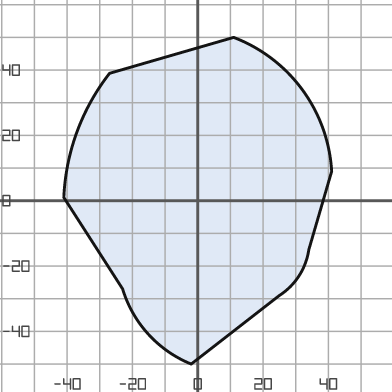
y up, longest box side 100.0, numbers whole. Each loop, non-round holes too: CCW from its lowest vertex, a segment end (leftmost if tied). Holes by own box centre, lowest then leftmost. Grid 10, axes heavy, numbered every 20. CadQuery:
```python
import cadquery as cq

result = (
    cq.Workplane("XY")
    .moveTo(-2.0, -50.0)
    .lineTo(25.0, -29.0)
    .threePointArc((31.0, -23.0), (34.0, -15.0))
    .lineTo(41.0, 9.0)
    .threePointArc((32.0, 34.0), (11.0, 50.0))
    .lineTo(-27.0, 39.0)
    .threePointArc((-37.0, 21.0), (-41.0, 1.0))
    .lineTo(-23.0, -27.0)
    .threePointArc((-15.0, -41.0), (-2.0, -50.0))
    .close()
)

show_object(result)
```